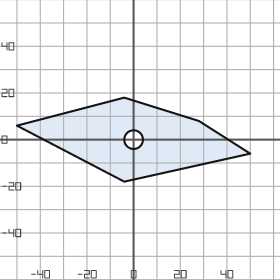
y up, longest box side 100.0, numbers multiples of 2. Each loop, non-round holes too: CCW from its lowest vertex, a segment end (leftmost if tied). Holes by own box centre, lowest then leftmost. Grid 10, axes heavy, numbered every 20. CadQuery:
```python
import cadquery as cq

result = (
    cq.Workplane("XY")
    .moveTo(-4.0, -18.0)
    .lineTo(50.0, -6.0)
    .lineTo(28.0, 8.0)
    .lineTo(-4.0, 18.0)
    .lineTo(-50.0, 6.0)
    .close()
    .moveTo(0.0, 0.0)
    .circle(4.0)
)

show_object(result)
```